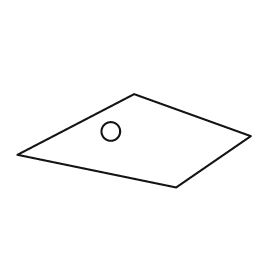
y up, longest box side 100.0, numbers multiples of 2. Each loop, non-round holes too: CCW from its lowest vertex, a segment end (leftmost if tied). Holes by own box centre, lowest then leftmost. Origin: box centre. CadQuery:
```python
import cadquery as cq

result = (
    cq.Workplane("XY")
    .moveTo(18.0, -20.0)
    .lineTo(50.0, 2.0)
    .lineTo(0.0, 20.0)
    .lineTo(-50.0, -6.0)
    .close()
    .moveTo(-10.0, 4.0)
    .circle(4.0)
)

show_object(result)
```